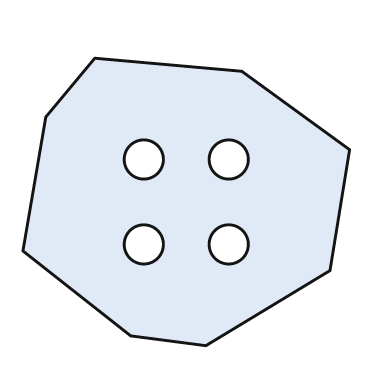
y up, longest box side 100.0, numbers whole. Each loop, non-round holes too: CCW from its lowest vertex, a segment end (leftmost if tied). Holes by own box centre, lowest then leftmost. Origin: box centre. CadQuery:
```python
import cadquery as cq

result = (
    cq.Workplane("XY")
    .moveTo(6.0, -44.0)
    .lineTo(44.0, -21.0)
    .lineTo(50.0, 16.0)
    .lineTo(17.0, 40.0)
    .lineTo(-28.0, 44.0)
    .lineTo(-43.0, 26.0)
    .lineTo(-50.0, -15.0)
    .lineTo(-17.0, -41.0)
    .close()
    .moveTo(-13.0, -13.0)
    .circle(6.0)
    .moveTo(13.0, -13.0)
    .circle(6.0)
    .moveTo(-13.0, 13.0)
    .circle(6.0)
    .moveTo(13.0, 13.0)
    .circle(6.0)
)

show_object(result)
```